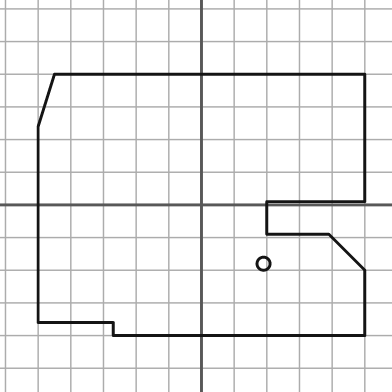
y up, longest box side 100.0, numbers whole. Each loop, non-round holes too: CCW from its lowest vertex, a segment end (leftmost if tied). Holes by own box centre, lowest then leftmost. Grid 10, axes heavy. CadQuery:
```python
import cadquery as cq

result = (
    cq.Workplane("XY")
    .moveTo(-27.0, -40.0)
    .lineTo(50.0, -40.0)
    .lineTo(50.0, -20.0)
    .lineTo(39.0, -9.0)
    .lineTo(20.0, -9.0)
    .lineTo(20.0, 1.0)
    .lineTo(50.0, 1.0)
    .lineTo(50.0, 40.0)
    .lineTo(-45.0, 40.0)
    .lineTo(-50.0, 24.0)
    .lineTo(-50.0, -36.0)
    .lineTo(-27.0, -36.0)
    .close()
    .moveTo(19.0, -18.0)
    .circle(2.0)
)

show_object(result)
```